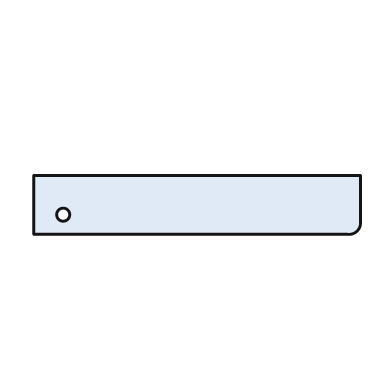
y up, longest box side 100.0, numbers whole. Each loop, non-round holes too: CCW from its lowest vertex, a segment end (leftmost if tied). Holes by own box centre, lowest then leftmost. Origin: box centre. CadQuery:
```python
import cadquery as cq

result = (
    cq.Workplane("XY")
    .moveTo(-50.0, -9.0)
    .lineTo(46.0, -9.0)
    .threePointArc((49.0, -8.0), (50.0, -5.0))
    .lineTo(50.0, 9.0)
    .lineTo(-50.0, 9.0)
    .close()
    .moveTo(-41.0, -3.0)
    .circle(2.0)
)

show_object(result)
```